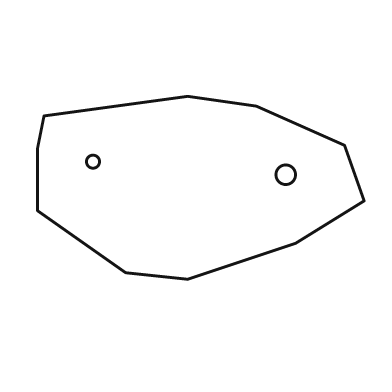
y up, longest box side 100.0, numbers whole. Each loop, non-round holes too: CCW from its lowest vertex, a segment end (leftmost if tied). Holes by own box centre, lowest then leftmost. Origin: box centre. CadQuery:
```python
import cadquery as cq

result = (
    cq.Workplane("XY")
    .moveTo(-4.0, -28.0)
    .lineTo(29.0, -17.0)
    .lineTo(50.0, -4.0)
    .lineTo(44.0, 13.0)
    .lineTo(17.0, 25.0)
    .lineTo(-4.0, 28.0)
    .lineTo(-48.0, 22.0)
    .lineTo(-50.0, 12.0)
    .lineTo(-50.0, -7.0)
    .lineTo(-23.0, -26.0)
    .close()
    .moveTo(26.0, 4.0)
    .circle(3.0)
    .moveTo(-33.0, 8.0)
    .circle(2.0)
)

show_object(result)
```